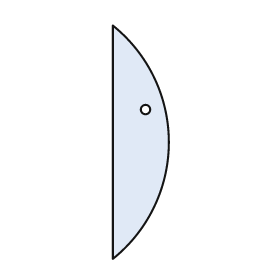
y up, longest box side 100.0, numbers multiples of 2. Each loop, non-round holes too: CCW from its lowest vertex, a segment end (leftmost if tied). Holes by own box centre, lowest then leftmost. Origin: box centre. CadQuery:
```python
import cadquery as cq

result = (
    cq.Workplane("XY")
    .moveTo(-12.0, -50.0)
    .threePointArc((12.0, 0.0), (-12.0, 50.0))
    .close()
    .moveTo(2.0, 14.0)
    .circle(2.0)
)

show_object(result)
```